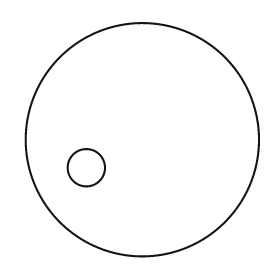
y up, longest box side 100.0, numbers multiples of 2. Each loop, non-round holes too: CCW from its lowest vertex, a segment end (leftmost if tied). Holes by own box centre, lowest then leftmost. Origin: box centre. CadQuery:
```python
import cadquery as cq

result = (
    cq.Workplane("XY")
    .moveTo(0.0, 0.0)
    .circle(50.0)
    .moveTo(-24.0, -12.0)
    .circle(8.0)
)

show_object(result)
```